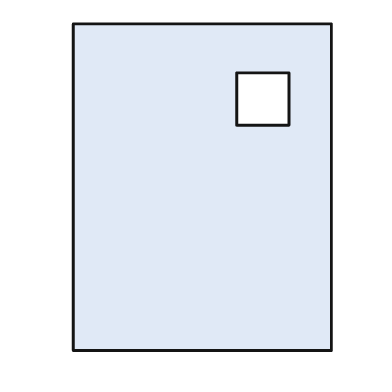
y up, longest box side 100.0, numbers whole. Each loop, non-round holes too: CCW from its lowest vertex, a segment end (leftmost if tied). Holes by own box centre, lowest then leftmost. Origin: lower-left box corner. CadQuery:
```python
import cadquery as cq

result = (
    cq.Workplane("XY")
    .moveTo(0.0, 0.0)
    .lineTo(79.0, 0.0)
    .lineTo(79.0, 100.0)
    .lineTo(0.0, 100.0)
    .close()
    .moveTo(50.0, 69.0)
    .lineTo(66.0, 69.0)
    .lineTo(66.0, 85.0)
    .lineTo(50.0, 85.0)
    .close()
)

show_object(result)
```